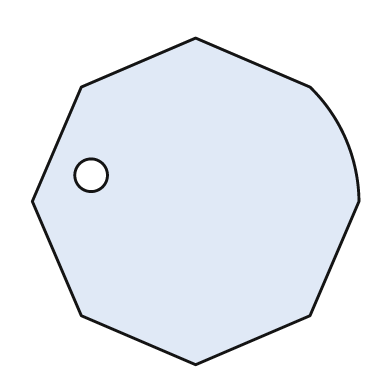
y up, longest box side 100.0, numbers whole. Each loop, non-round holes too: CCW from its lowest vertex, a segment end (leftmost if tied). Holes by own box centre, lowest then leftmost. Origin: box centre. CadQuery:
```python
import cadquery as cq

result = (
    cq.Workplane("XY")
    .moveTo(0.0, -50.0)
    .lineTo(35.0, -35.0)
    .lineTo(50.0, 0.0)
    .threePointArc((46.0, 19.0), (35.0, 35.0))
    .lineTo(0.0, 50.0)
    .lineTo(-35.0, 35.0)
    .lineTo(-50.0, 0.0)
    .lineTo(-35.0, -35.0)
    .close()
    .moveTo(-32.0, 8.0)
    .circle(5.0)
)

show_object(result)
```